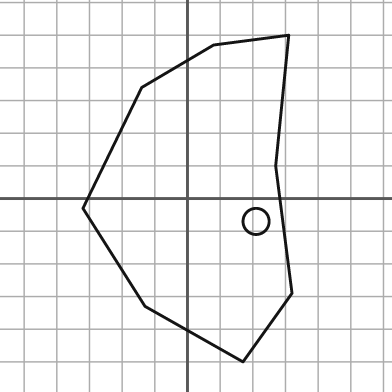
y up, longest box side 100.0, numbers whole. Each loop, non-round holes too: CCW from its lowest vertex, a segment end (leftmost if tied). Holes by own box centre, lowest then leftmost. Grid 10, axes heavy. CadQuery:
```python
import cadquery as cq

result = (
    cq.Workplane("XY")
    .moveTo(17.0, -50.0)
    .lineTo(32.0, -29.0)
    .lineTo(27.0, 10.0)
    .lineTo(31.0, 50.0)
    .lineTo(8.0, 47.0)
    .lineTo(-14.0, 34.0)
    .lineTo(-32.0, -3.0)
    .lineTo(-13.0, -33.0)
    .close()
    .moveTo(21.0, -7.0)
    .circle(4.0)
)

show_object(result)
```